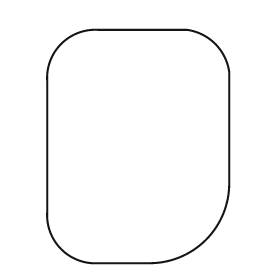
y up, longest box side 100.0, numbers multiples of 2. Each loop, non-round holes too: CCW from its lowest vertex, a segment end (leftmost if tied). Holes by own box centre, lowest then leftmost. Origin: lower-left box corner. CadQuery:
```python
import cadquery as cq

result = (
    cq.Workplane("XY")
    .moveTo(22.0, 0.0)
    .lineTo(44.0, 0.0)
    .threePointArc((68.0, 10.0), (78.0, 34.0))
    .lineTo(78.0, 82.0)
    .threePointArc((72.0, 94.0), (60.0, 100.0))
    .lineTo(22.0, 100.0)
    .threePointArc((6.0, 94.0), (0.0, 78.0))
    .lineTo(0.0, 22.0)
    .threePointArc((6.0, 6.0), (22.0, 0.0))
    .close()
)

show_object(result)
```